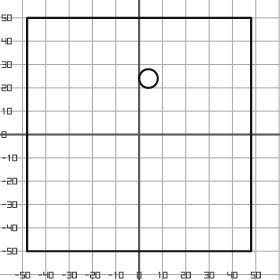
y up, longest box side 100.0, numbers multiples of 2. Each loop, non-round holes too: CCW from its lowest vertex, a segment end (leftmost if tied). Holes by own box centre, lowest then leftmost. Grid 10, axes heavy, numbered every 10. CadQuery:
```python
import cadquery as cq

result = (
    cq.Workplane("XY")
    .moveTo(-48.0, -50.0)
    .lineTo(48.0, -50.0)
    .lineTo(48.0, 50.0)
    .lineTo(-48.0, 50.0)
    .close()
    .moveTo(4.0, 24.0)
    .circle(4.0)
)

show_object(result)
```